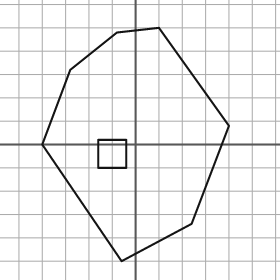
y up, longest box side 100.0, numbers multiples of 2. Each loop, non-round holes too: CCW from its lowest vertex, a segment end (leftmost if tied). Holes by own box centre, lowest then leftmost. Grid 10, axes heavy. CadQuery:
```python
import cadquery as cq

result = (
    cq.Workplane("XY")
    .moveTo(-6.0, -50.0)
    .lineTo(24.0, -34.0)
    .lineTo(40.0, 8.0)
    .lineTo(10.0, 50.0)
    .lineTo(-8.0, 48.0)
    .lineTo(-28.0, 32.0)
    .lineTo(-40.0, 0.0)
    .close()
    .moveTo(-16.0, -10.0)
    .lineTo(-4.0, -10.0)
    .lineTo(-4.0, 2.0)
    .lineTo(-16.0, 2.0)
    .close()
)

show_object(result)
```